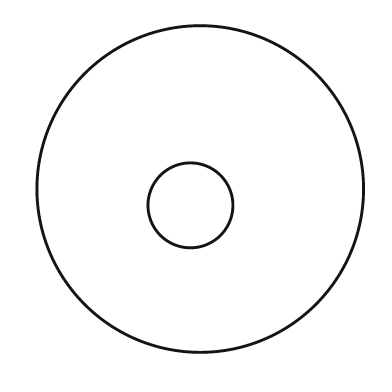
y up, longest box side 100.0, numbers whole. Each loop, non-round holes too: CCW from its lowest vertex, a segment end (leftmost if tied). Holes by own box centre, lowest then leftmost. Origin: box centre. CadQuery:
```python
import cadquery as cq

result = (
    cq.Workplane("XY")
    .moveTo(0.0, 0.0)
    .circle(50.0)
    .moveTo(-3.0, -5.0)
    .circle(13.0)
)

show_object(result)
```